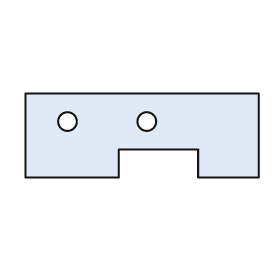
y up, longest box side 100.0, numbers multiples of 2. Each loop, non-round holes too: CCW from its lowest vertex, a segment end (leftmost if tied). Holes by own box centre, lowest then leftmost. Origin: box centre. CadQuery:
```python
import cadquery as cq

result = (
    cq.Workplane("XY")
    .moveTo(-50.0, -18.0)
    .lineTo(-10.0, -18.0)
    .lineTo(-10.0, -6.0)
    .lineTo(24.0, -6.0)
    .lineTo(24.0, -18.0)
    .lineTo(50.0, -18.0)
    .lineTo(50.0, 18.0)
    .lineTo(-50.0, 18.0)
    .close()
    .moveTo(-32.0, 6.0)
    .circle(4.0)
    .moveTo(2.0, 6.0)
    .circle(4.0)
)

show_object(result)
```